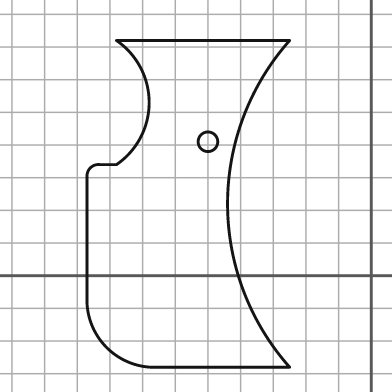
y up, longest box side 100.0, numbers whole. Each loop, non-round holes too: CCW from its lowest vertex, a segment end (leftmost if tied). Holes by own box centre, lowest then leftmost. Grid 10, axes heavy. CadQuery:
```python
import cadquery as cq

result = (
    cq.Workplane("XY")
    .moveTo(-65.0, -28.0)
    .lineTo(-25.0, -28.0)
    .threePointArc((-44.0, 22.0), (-25.0, 72.0))
    .lineTo(-78.0, 72.0)
    .threePointArc((-68.0, 53.0), (-78.0, 34.0))
    .lineTo(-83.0, 34.0)
    .threePointArc((-86.0, 33.0), (-87.0, 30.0))
    .lineTo(-87.0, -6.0)
    .threePointArc((-81.0, -22.0), (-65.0, -28.0))
    .close()
    .moveTo(-50.0, 41.0)
    .circle(3.0)
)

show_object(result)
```